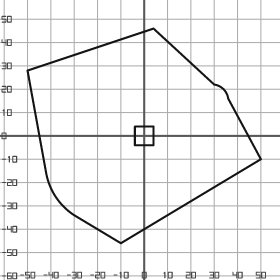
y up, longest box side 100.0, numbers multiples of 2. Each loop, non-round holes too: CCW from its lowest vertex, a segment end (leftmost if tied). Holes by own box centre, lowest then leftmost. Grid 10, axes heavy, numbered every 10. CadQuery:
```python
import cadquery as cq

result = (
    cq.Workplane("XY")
    .moveTo(-10.0, -46.0)
    .lineTo(50.0, -10.0)
    .lineTo(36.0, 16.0)
    .threePointArc((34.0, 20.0), (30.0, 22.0))
    .lineTo(4.0, 46.0)
    .lineTo(-50.0, 28.0)
    .lineTo(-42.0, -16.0)
    .threePointArc((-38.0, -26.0), (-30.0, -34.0))
    .close()
    .moveTo(-4.0, -4.0)
    .lineTo(4.0, -4.0)
    .lineTo(4.0, 4.0)
    .lineTo(-4.0, 4.0)
    .close()
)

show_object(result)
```